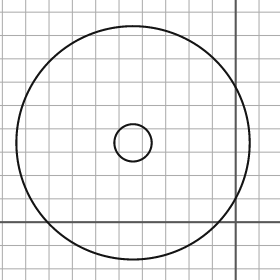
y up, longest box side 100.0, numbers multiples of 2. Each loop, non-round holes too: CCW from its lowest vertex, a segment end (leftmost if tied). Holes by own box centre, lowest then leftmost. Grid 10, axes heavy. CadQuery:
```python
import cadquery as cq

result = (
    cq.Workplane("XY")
    .moveTo(-44.0, 34.0)
    .circle(50.0)
    .moveTo(-44.0, 34.0)
    .circle(8.0)
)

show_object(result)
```